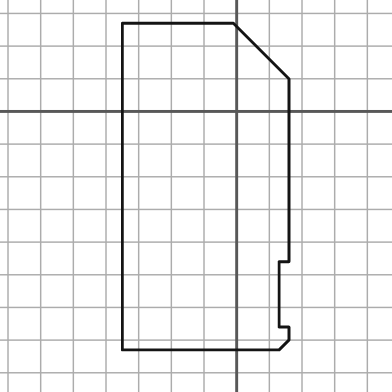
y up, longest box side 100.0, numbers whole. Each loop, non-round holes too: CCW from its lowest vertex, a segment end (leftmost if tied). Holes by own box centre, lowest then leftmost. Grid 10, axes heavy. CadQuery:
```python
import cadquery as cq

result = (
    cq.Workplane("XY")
    .moveTo(-35.0, -73.0)
    .lineTo(13.0, -73.0)
    .lineTo(16.0, -70.0)
    .lineTo(16.0, -66.0)
    .lineTo(13.0, -66.0)
    .lineTo(13.0, -46.0)
    .lineTo(16.0, -46.0)
    .lineTo(16.0, 10.0)
    .lineTo(-1.0, 27.0)
    .lineTo(-35.0, 27.0)
    .close()
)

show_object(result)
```